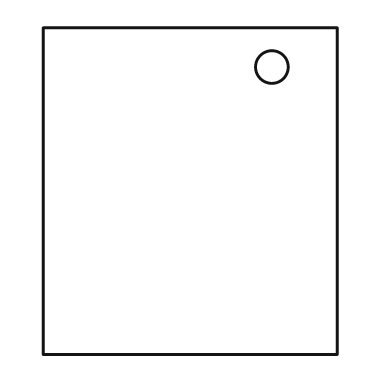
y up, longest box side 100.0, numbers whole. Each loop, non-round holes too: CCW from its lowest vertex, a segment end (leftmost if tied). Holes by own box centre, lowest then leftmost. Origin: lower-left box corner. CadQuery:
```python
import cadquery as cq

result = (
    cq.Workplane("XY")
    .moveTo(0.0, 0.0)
    .lineTo(90.0, 0.0)
    .lineTo(90.0, 100.0)
    .lineTo(0.0, 100.0)
    .close()
    .moveTo(70.0, 88.0)
    .circle(5.0)
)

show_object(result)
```